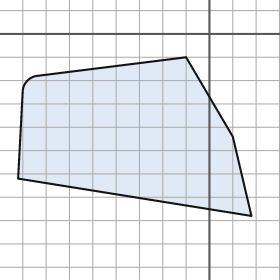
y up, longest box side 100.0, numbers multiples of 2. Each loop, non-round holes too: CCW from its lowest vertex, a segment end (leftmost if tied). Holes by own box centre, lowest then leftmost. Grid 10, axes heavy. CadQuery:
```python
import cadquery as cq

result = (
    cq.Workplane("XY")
    .moveTo(18.0, -78.0)
    .lineTo(10.0, -44.0)
    .lineTo(-10.0, -10.0)
    .lineTo(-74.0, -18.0)
    .threePointArc((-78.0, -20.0), (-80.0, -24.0))
    .lineTo(-82.0, -62.0)
    .close()
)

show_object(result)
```